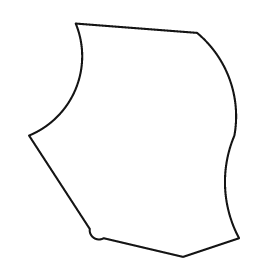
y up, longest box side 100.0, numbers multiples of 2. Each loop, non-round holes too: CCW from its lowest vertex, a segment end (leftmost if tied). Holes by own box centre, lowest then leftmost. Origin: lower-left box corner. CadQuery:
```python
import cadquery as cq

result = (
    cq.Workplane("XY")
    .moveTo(66.0, 0.0)
    .lineTo(90.0, 8.0)
    .threePointArc((84.0, 30.0), (88.0, 52.0))
    .threePointArc((86.0, 76.0), (72.0, 96.0))
    .lineTo(20.0, 100.0)
    .threePointArc((20.0, 72.0), (0.0, 52.0))
    .lineTo(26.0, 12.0)
    .threePointArc((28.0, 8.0), (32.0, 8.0))
    .close()
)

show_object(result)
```